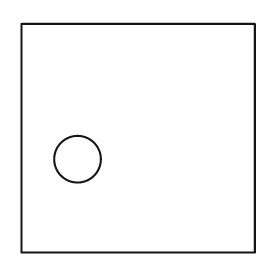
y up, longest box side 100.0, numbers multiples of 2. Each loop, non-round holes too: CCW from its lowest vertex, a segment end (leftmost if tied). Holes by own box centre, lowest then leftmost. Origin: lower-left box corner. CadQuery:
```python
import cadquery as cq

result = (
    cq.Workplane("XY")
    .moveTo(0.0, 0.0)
    .lineTo(100.0, 0.0)
    .lineTo(100.0, 98.0)
    .lineTo(0.0, 98.0)
    .close()
    .moveTo(24.0, 40.0)
    .circle(10.0)
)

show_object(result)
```